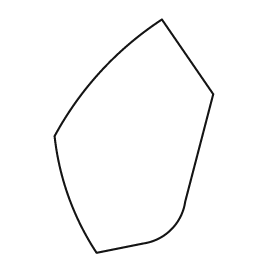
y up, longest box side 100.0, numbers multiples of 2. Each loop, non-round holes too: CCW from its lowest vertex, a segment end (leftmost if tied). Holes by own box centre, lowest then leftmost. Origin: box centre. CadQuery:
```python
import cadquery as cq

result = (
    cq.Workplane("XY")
    .moveTo(-16.0, -50.0)
    .lineTo(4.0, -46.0)
    .threePointArc((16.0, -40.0), (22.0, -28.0))
    .lineTo(34.0, 18.0)
    .lineTo(12.0, 50.0)
    .threePointArc((-14.0, 28.0), (-34.0, 0.0))
    .threePointArc((-28.0, -26.0), (-16.0, -50.0))
    .close()
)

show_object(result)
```